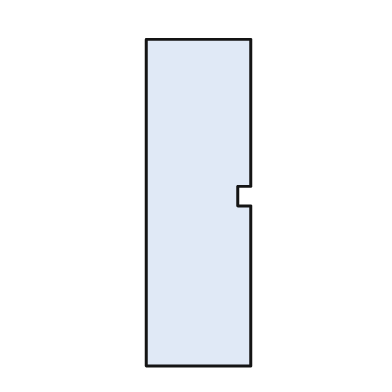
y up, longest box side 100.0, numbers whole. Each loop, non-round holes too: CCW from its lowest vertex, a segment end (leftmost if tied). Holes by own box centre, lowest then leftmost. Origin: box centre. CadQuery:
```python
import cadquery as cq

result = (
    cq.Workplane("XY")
    .moveTo(-16.0, -50.0)
    .lineTo(16.0, -50.0)
    .lineTo(16.0, -1.0)
    .lineTo(12.0, -1.0)
    .lineTo(12.0, 5.0)
    .lineTo(16.0, 5.0)
    .lineTo(16.0, 50.0)
    .lineTo(-16.0, 50.0)
    .close()
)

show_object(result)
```